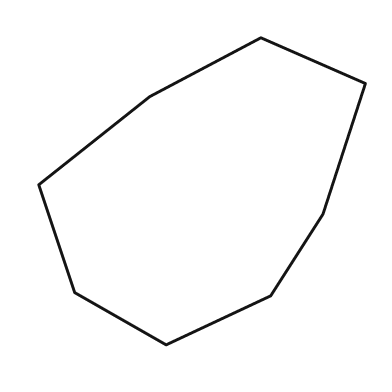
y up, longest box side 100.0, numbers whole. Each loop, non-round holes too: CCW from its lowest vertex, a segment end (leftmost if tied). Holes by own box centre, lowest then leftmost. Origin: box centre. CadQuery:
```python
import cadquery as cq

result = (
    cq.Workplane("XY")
    .moveTo(-11.0, -47.0)
    .lineTo(21.0, -32.0)
    .lineTo(37.0, -7.0)
    .lineTo(50.0, 33.0)
    .lineTo(18.0, 47.0)
    .lineTo(-16.0, 29.0)
    .lineTo(-50.0, 2.0)
    .lineTo(-39.0, -31.0)
    .close()
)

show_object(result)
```